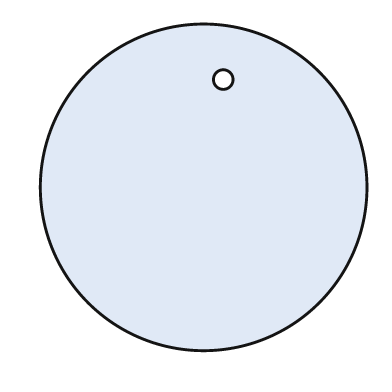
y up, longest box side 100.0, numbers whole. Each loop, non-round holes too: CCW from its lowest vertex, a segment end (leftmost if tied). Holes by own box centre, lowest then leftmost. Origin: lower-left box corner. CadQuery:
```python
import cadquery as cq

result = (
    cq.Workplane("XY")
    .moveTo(50.0, 50.0)
    .circle(50.0)
    .moveTo(56.0, 83.0)
    .circle(3.0)
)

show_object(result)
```